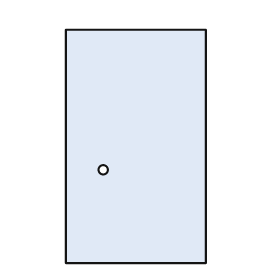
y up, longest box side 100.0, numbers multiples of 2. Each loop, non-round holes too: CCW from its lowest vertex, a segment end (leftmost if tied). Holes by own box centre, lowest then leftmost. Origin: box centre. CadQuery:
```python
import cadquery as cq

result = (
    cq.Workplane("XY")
    .moveTo(-30.0, -50.0)
    .lineTo(30.0, -50.0)
    .lineTo(30.0, 50.0)
    .lineTo(-30.0, 50.0)
    .close()
    .moveTo(-14.0, -10.0)
    .circle(2.0)
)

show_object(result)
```